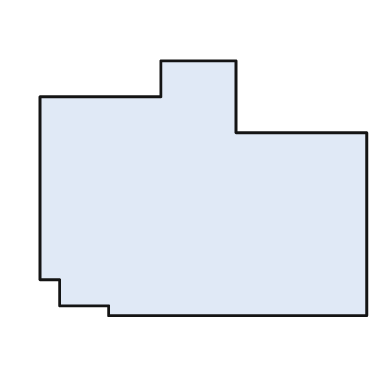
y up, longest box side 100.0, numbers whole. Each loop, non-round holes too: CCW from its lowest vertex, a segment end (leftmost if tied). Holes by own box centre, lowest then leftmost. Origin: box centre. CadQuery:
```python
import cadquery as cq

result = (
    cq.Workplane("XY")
    .moveTo(-29.0, -39.0)
    .lineTo(50.0, -39.0)
    .lineTo(50.0, 17.0)
    .lineTo(10.0, 17.0)
    .lineTo(10.0, 39.0)
    .lineTo(-13.0, 39.0)
    .lineTo(-13.0, 28.0)
    .lineTo(-50.0, 28.0)
    .lineTo(-50.0, -28.0)
    .lineTo(-44.0, -28.0)
    .lineTo(-44.0, -36.0)
    .lineTo(-29.0, -36.0)
    .close()
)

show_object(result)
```